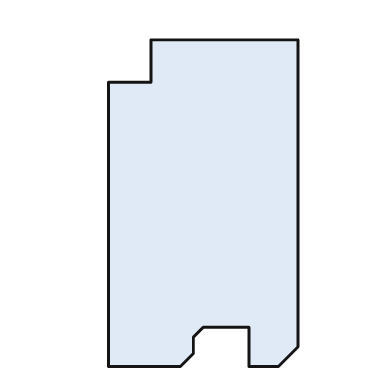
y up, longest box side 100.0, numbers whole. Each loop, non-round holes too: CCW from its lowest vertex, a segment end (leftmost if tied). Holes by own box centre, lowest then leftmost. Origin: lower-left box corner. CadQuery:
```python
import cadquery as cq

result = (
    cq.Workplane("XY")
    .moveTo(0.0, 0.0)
    .lineTo(22.0, 0.0)
    .lineTo(26.0, 4.0)
    .lineTo(26.0, 9.0)
    .lineTo(29.0, 12.0)
    .lineTo(43.0, 12.0)
    .lineTo(43.0, 0.0)
    .lineTo(52.0, 0.0)
    .lineTo(58.0, 6.0)
    .lineTo(58.0, 100.0)
    .lineTo(13.0, 100.0)
    .lineTo(13.0, 87.0)
    .lineTo(0.0, 87.0)
    .close()
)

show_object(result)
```